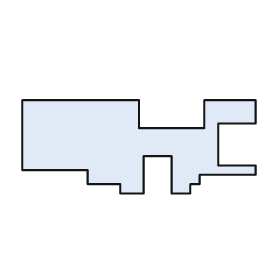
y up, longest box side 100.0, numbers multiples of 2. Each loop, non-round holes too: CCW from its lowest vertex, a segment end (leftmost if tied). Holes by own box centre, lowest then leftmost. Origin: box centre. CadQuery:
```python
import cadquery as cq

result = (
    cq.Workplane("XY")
    .moveTo(-8.0, -20.0)
    .lineTo(2.0, -20.0)
    .lineTo(2.0, -4.0)
    .lineTo(14.0, -4.0)
    .lineTo(14.0, -20.0)
    .lineTo(22.0, -20.0)
    .lineTo(22.0, -16.0)
    .lineTo(26.0, -16.0)
    .lineTo(26.0, -12.0)
    .lineTo(50.0, -12.0)
    .lineTo(50.0, -8.0)
    .lineTo(34.0, -8.0)
    .lineTo(34.0, 10.0)
    .lineTo(50.0, 10.0)
    .lineTo(50.0, 20.0)
    .lineTo(28.0, 20.0)
    .lineTo(28.0, 8.0)
    .lineTo(0.0, 8.0)
    .lineTo(0.0, 20.0)
    .lineTo(-50.0, 20.0)
    .lineTo(-50.0, -10.0)
    .lineTo(-22.0, -10.0)
    .lineTo(-22.0, -16.0)
    .lineTo(-8.0, -16.0)
    .close()
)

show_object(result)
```